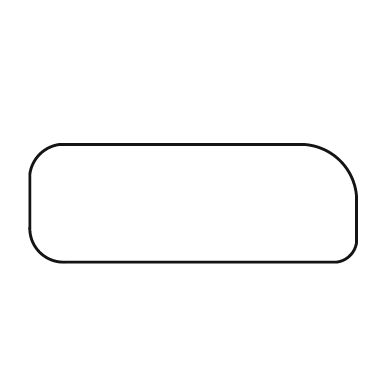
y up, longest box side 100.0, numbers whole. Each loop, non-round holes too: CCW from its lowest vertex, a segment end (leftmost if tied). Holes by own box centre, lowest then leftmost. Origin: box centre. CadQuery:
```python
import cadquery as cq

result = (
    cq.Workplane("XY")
    .moveTo(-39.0, -18.0)
    .lineTo(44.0, -18.0)
    .threePointArc((48.0, -16.0), (50.0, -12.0))
    .lineTo(50.0, 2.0)
    .threePointArc((45.0, 13.0), (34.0, 18.0))
    .lineTo(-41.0, 18.0)
    .threePointArc((-47.0, 15.0), (-50.0, 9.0))
    .lineTo(-50.0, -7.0)
    .threePointArc((-47.0, -15.0), (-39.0, -18.0))
    .close()
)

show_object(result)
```